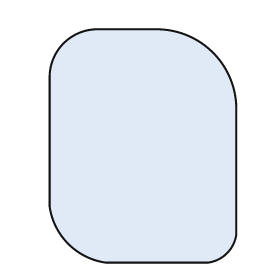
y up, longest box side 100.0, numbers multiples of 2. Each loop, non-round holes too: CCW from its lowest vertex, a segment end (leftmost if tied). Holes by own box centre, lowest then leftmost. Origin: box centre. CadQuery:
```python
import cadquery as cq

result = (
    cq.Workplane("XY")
    .moveTo(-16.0, -50.0)
    .lineTo(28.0, -50.0)
    .threePointArc((36.0, -46.0), (40.0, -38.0))
    .lineTo(40.0, 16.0)
    .threePointArc((30.0, 40.0), (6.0, 50.0))
    .lineTo(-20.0, 50.0)
    .threePointArc((-34.0, 44.0), (-40.0, 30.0))
    .lineTo(-40.0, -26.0)
    .threePointArc((-32.0, -42.0), (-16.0, -50.0))
    .close()
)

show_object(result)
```